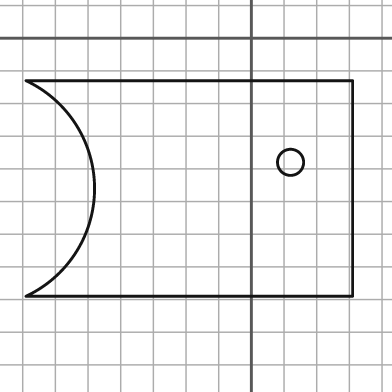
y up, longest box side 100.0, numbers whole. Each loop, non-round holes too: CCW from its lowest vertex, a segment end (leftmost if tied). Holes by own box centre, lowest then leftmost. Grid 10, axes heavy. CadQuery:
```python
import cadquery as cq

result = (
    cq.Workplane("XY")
    .moveTo(-69.0, -79.0)
    .lineTo(31.0, -79.0)
    .lineTo(31.0, -13.0)
    .lineTo(-69.0, -13.0)
    .threePointArc((-48.0, -46.0), (-69.0, -79.0))
    .close()
    .moveTo(12.0, -38.0)
    .circle(4.0)
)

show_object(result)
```